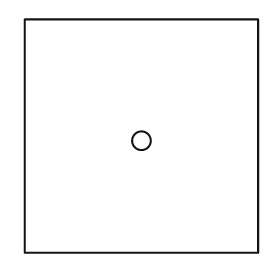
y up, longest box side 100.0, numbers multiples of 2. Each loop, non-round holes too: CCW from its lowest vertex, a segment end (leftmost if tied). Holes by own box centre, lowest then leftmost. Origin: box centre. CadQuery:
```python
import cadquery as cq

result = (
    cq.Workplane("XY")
    .moveTo(-50.0, -50.0)
    .lineTo(50.0, -50.0)
    .lineTo(50.0, 50.0)
    .lineTo(-50.0, 50.0)
    .close()
    .moveTo(0.0, -2.0)
    .circle(4.0)
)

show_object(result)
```